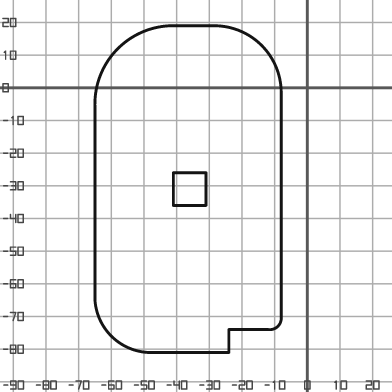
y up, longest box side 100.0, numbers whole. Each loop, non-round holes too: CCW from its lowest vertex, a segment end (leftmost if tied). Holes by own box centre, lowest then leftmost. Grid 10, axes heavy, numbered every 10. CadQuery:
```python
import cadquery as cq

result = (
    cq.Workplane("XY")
    .moveTo(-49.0, -81.0)
    .lineTo(-24.0, -81.0)
    .lineTo(-24.0, -74.0)
    .lineTo(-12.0, -74.0)
    .threePointArc((-9.0, -73.0), (-8.0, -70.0))
    .lineTo(-8.0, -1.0)
    .threePointArc((-14.0, 13.0), (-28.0, 19.0))
    .lineTo(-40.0, 19.0)
    .threePointArc((-58.0, 12.0), (-65.0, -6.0))
    .lineTo(-65.0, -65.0)
    .threePointArc((-60.0, -76.0), (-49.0, -81.0))
    .close()
    .moveTo(-41.0, -36.0)
    .lineTo(-31.0, -36.0)
    .lineTo(-31.0, -26.0)
    .lineTo(-41.0, -26.0)
    .close()
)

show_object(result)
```